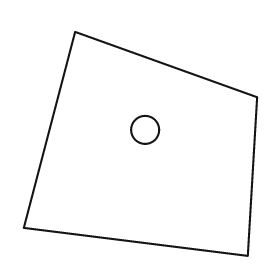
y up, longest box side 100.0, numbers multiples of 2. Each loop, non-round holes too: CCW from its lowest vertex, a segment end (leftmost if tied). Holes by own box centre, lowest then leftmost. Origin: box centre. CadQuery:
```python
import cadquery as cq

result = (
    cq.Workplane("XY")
    .moveTo(46.0, -48.0)
    .lineTo(50.0, 20.0)
    .lineTo(-28.0, 48.0)
    .lineTo(-50.0, -36.0)
    .close()
    .moveTo(2.0, 6.0)
    .circle(6.0)
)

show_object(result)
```